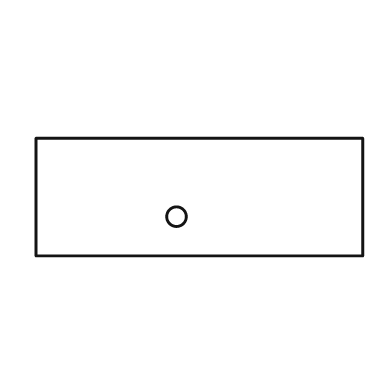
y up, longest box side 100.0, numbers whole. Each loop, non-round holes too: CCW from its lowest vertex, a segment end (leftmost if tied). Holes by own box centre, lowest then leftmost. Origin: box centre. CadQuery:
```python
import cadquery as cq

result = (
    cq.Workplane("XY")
    .moveTo(-50.0, -18.0)
    .lineTo(50.0, -18.0)
    .lineTo(50.0, 18.0)
    .lineTo(-50.0, 18.0)
    .close()
    .moveTo(-7.0, -6.0)
    .circle(3.0)
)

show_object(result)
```